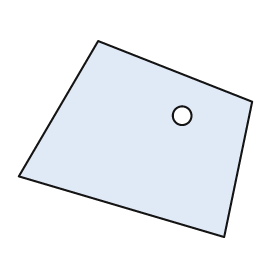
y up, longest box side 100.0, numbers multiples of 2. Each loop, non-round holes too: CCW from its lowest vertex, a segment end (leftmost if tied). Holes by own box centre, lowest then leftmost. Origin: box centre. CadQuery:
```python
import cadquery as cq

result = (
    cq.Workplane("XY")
    .moveTo(38.0, -42.0)
    .lineTo(50.0, 16.0)
    .lineTo(-16.0, 42.0)
    .lineTo(-50.0, -16.0)
    .close()
    .moveTo(20.0, 10.0)
    .circle(4.0)
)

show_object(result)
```